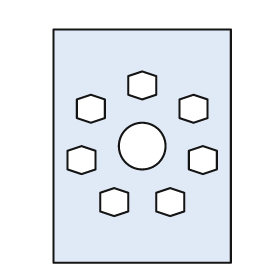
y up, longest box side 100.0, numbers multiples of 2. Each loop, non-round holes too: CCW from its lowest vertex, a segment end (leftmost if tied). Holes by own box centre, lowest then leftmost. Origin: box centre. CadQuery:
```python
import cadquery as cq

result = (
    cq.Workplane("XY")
    .moveTo(-38.0, -50.0)
    .lineTo(38.0, -50.0)
    .lineTo(38.0, 50.0)
    .lineTo(-38.0, 50.0)
    .close()
    .moveTo(-12.0, -30.0)
    .lineTo(-6.0, -28.0)
    .lineTo(-6.0, -20.0)
    .lineTo(-12.0, -18.0)
    .lineTo(-18.0, -20.0)
    .lineTo(-18.0, -28.0)
    .close()
    .moveTo(12.0, -30.0)
    .lineTo(18.0, -28.0)
    .lineTo(18.0, -20.0)
    .lineTo(12.0, -18.0)
    .lineTo(6.0, -20.0)
    .lineTo(6.0, -28.0)
    .close()
    .moveTo(-26.0, -12.0)
    .lineTo(-20.0, -10.0)
    .lineTo(-20.0, -2.0)
    .lineTo(-26.0, 0.0)
    .lineTo(-32.0, -2.0)
    .lineTo(-32.0, -10.0)
    .close()
    .moveTo(26.0, -12.0)
    .lineTo(32.0, -10.0)
    .lineTo(32.0, -2.0)
    .lineTo(26.0, 0.0)
    .lineTo(20.0, -2.0)
    .lineTo(20.0, -10.0)
    .close()
    .moveTo(0.0, 0.0)
    .circle(10.0)
    .moveTo(-22.0, 10.0)
    .lineTo(-16.0, 12.0)
    .lineTo(-16.0, 20.0)
    .lineTo(-22.0, 22.0)
    .lineTo(-28.0, 20.0)
    .lineTo(-28.0, 12.0)
    .close()
    .moveTo(22.0, 10.0)
    .lineTo(28.0, 12.0)
    .lineTo(28.0, 20.0)
    .lineTo(22.0, 22.0)
    .lineTo(16.0, 20.0)
    .lineTo(16.0, 12.0)
    .close()
    .moveTo(0.0, 20.0)
    .lineTo(6.0, 22.0)
    .lineTo(6.0, 30.0)
    .lineTo(0.0, 32.0)
    .lineTo(-6.0, 30.0)
    .lineTo(-6.0, 22.0)
    .close()
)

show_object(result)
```